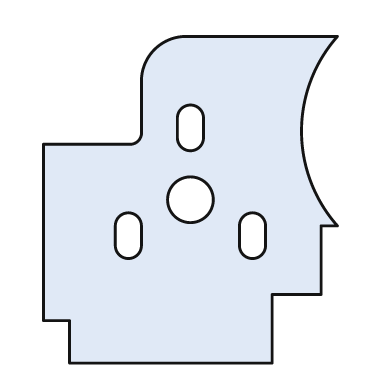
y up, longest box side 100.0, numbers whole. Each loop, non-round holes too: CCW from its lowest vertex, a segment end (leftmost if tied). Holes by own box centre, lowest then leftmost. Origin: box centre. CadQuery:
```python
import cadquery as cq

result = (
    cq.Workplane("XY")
    .moveTo(-37.0, -50.0)
    .lineTo(25.0, -50.0)
    .lineTo(25.0, -29.0)
    .lineTo(40.0, -29.0)
    .lineTo(40.0, -8.0)
    .lineTo(45.0, -8.0)
    .threePointArc((34.0, 21.0), (45.0, 50.0))
    .lineTo(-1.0, 50.0)
    .threePointArc((-11.0, 46.0), (-15.0, 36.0))
    .lineTo(-15.0, 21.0)
    .threePointArc((-16.0, 18.0), (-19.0, 17.0))
    .lineTo(-45.0, 17.0)
    .lineTo(-45.0, -37.0)
    .lineTo(-37.0, -37.0)
    .close()
    .moveTo(-23.0, -14.0)
    .threePointArc((-19.0, -18.0), (-15.0, -14.0))
    .lineTo(-15.0, -8.0)
    .threePointArc((-19.0, -4.0), (-23.0, -8.0))
    .close()
    .moveTo(15.0, -14.0)
    .threePointArc((19.0, -18.0), (23.0, -14.0))
    .lineTo(23.0, -8.0)
    .threePointArc((19.0, -4.0), (15.0, -8.0))
    .close()
    .moveTo(0.0, 0.0)
    .circle(7.0)
    .moveTo(-4.0, 19.0)
    .threePointArc((0.0, 15.0), (4.0, 19.0))
    .lineTo(4.0, 25.0)
    .threePointArc((0.0, 29.0), (-4.0, 25.0))
    .close()
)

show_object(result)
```